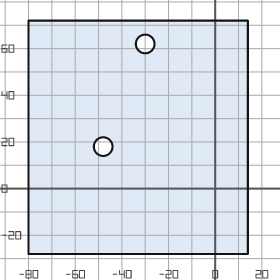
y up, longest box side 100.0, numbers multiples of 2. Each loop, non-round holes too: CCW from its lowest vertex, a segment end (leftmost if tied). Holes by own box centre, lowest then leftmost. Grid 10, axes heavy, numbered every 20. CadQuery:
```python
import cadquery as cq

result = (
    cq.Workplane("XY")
    .moveTo(-80.0, -28.0)
    .lineTo(14.0, -28.0)
    .lineTo(14.0, 72.0)
    .lineTo(-80.0, 72.0)
    .close()
    .moveTo(-48.0, 18.0)
    .circle(4.0)
    .moveTo(-30.0, 62.0)
    .circle(4.0)
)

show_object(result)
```